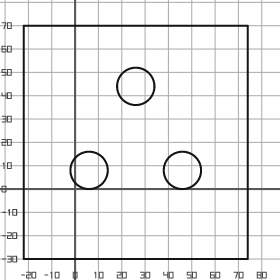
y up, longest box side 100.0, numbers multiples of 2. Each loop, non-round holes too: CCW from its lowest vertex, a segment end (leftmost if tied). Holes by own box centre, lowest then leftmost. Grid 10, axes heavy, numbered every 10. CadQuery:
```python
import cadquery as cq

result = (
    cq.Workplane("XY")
    .moveTo(-22.0, -30.0)
    .lineTo(74.0, -30.0)
    .lineTo(74.0, 70.0)
    .lineTo(-22.0, 70.0)
    .close()
    .moveTo(6.0, 8.0)
    .circle(8.0)
    .moveTo(46.0, 8.0)
    .circle(8.0)
    .moveTo(26.0, 44.0)
    .circle(8.0)
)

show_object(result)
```